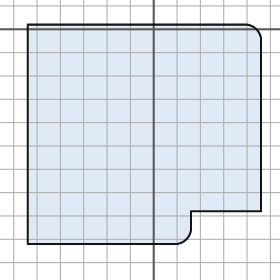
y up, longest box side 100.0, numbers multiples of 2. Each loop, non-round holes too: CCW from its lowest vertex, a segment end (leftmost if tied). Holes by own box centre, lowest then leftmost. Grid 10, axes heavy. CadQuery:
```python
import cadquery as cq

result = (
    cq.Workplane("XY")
    .moveTo(-54.0, -92.0)
    .lineTo(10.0, -92.0)
    .threePointArc((14.0, -90.0), (16.0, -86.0))
    .lineTo(16.0, -78.0)
    .lineTo(46.0, -78.0)
    .lineTo(46.0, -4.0)
    .threePointArc((44.0, 0.0), (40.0, 2.0))
    .lineTo(-54.0, 2.0)
    .close()
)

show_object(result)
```